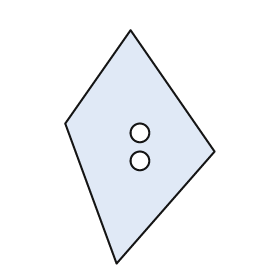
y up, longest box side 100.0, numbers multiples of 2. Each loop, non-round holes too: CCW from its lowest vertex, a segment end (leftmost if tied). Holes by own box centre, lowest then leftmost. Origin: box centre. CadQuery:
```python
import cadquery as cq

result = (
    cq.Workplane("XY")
    .moveTo(-10.0, -50.0)
    .lineTo(32.0, -2.0)
    .lineTo(-4.0, 50.0)
    .lineTo(-32.0, 10.0)
    .close()
    .moveTo(0.0, -6.0)
    .circle(4.0)
    .moveTo(0.0, 6.0)
    .circle(4.0)
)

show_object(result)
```